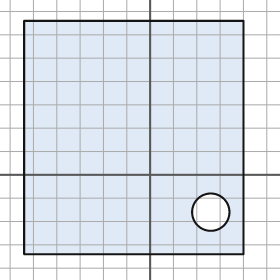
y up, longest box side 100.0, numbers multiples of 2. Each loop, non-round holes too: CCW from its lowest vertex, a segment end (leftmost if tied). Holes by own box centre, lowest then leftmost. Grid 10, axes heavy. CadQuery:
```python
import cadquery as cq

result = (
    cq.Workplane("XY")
    .moveTo(-54.0, -34.0)
    .lineTo(40.0, -34.0)
    .lineTo(40.0, 66.0)
    .lineTo(-54.0, 66.0)
    .close()
    .moveTo(26.0, -16.0)
    .circle(8.0)
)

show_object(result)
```